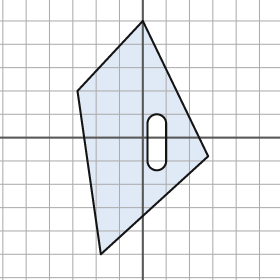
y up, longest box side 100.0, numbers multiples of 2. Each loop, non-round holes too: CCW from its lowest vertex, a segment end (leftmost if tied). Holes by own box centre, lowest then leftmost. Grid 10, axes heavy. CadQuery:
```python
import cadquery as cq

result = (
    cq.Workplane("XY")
    .moveTo(-18.0, -50.0)
    .lineTo(28.0, -8.0)
    .lineTo(0.0, 50.0)
    .lineTo(-28.0, 20.0)
    .close()
    .moveTo(2.0, -10.0)
    .threePointArc((6.0, -14.0), (10.0, -10.0))
    .lineTo(10.0, 6.0)
    .threePointArc((6.0, 10.0), (2.0, 6.0))
    .close()
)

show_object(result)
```